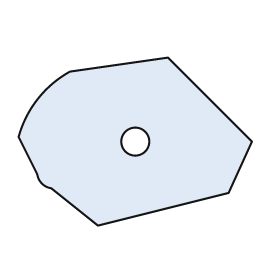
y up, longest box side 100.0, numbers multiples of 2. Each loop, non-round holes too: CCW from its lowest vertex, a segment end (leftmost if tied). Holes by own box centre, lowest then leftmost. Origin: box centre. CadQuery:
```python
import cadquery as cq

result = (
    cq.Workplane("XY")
    .moveTo(-16.0, -36.0)
    .lineTo(40.0, -22.0)
    .lineTo(50.0, 0.0)
    .lineTo(14.0, 36.0)
    .lineTo(-28.0, 30.0)
    .threePointArc((-42.0, 18.0), (-50.0, 2.0))
    .lineTo(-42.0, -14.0)
    .threePointArc((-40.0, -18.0), (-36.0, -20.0))
    .close()
    .moveTo(0.0, 0.0)
    .circle(6.0)
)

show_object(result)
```